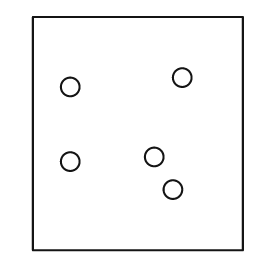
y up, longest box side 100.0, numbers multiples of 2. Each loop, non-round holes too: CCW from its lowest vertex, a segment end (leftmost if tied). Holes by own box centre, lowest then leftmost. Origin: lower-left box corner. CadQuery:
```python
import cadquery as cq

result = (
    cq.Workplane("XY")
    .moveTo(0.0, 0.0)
    .lineTo(90.0, 0.0)
    .lineTo(90.0, 100.0)
    .lineTo(0.0, 100.0)
    .close()
    .moveTo(60.0, 26.0)
    .circle(4.0)
    .moveTo(16.0, 38.0)
    .circle(4.0)
    .moveTo(52.0, 40.0)
    .circle(4.0)
    .moveTo(16.0, 70.0)
    .circle(4.0)
    .moveTo(64.0, 74.0)
    .circle(4.0)
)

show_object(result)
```